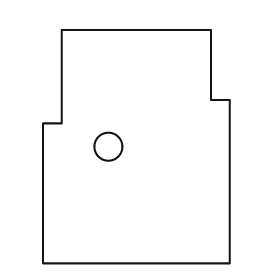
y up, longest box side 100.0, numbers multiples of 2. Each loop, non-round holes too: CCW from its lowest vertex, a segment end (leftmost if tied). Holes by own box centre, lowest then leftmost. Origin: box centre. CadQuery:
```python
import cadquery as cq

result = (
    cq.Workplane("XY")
    .moveTo(-40.0, -50.0)
    .lineTo(40.0, -50.0)
    .lineTo(40.0, 20.0)
    .lineTo(32.0, 20.0)
    .lineTo(32.0, 50.0)
    .lineTo(-32.0, 50.0)
    .lineTo(-32.0, 10.0)
    .lineTo(-40.0, 10.0)
    .close()
    .moveTo(-12.0, 0.0)
    .circle(6.0)
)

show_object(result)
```